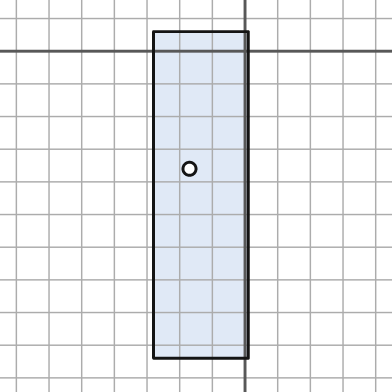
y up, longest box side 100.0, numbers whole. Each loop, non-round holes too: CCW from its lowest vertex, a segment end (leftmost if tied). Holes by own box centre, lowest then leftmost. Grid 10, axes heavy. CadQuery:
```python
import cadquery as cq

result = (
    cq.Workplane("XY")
    .moveTo(-28.0, -94.0)
    .lineTo(1.0, -94.0)
    .lineTo(1.0, 6.0)
    .lineTo(-28.0, 6.0)
    .close()
    .moveTo(-17.0, -36.0)
    .circle(2.0)
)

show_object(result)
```